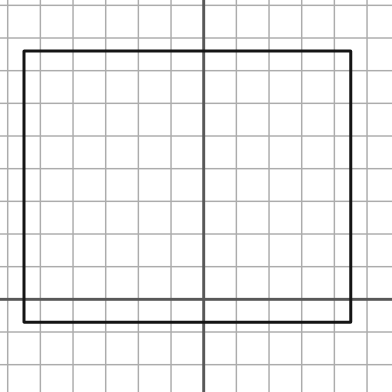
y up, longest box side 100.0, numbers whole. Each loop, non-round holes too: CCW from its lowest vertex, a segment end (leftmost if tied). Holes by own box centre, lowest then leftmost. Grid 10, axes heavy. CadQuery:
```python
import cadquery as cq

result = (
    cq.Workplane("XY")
    .moveTo(-55.0, -7.0)
    .lineTo(45.0, -7.0)
    .lineTo(45.0, 76.0)
    .lineTo(-55.0, 76.0)
    .close()
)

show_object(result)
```